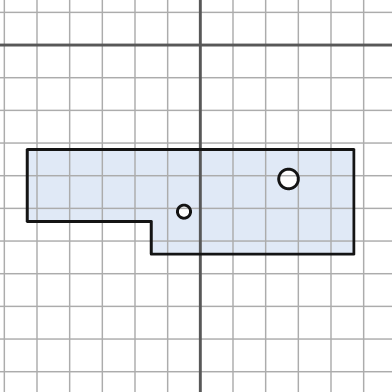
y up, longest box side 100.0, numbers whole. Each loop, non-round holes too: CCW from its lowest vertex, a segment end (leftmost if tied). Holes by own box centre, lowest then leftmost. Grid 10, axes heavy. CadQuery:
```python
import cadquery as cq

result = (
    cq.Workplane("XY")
    .moveTo(-15.0, -64.0)
    .lineTo(47.0, -64.0)
    .lineTo(47.0, -32.0)
    .lineTo(-53.0, -32.0)
    .lineTo(-53.0, -54.0)
    .lineTo(-15.0, -54.0)
    .close()
    .moveTo(-5.0, -51.0)
    .circle(2.0)
    .moveTo(27.0, -41.0)
    .circle(3.0)
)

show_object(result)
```